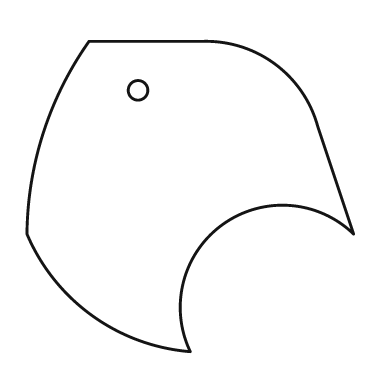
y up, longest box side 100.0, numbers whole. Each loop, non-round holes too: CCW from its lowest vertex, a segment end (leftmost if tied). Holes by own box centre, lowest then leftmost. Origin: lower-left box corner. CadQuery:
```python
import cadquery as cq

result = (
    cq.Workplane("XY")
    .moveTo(50.0, 0.0)
    .threePointArc((60.0, 39.0), (100.0, 36.0))
    .lineTo(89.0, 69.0)
    .threePointArc((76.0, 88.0), (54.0, 95.0))
    .lineTo(19.0, 95.0)
    .threePointArc((5.0, 67.0), (0.0, 36.0))
    .threePointArc((20.0, 11.0), (50.0, 0.0))
    .close()
    .moveTo(34.0, 80.0)
    .circle(3.0)
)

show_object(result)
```